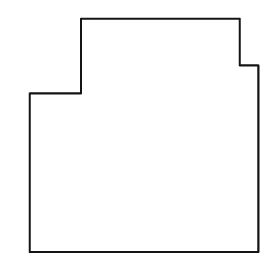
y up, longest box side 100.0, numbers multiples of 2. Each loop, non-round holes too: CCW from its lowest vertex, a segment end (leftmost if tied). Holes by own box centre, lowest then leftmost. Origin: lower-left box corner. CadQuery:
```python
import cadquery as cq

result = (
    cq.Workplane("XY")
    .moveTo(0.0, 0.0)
    .lineTo(98.0, 0.0)
    .lineTo(98.0, 80.0)
    .lineTo(90.0, 80.0)
    .lineTo(90.0, 100.0)
    .lineTo(22.0, 100.0)
    .lineTo(22.0, 68.0)
    .lineTo(0.0, 68.0)
    .close()
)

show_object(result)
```